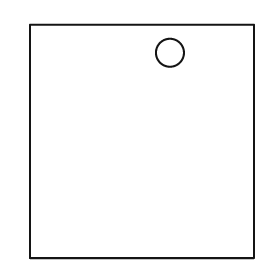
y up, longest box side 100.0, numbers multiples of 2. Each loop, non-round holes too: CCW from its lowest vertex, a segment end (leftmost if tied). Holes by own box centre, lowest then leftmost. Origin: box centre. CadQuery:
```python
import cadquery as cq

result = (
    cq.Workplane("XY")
    .moveTo(-48.0, -50.0)
    .lineTo(48.0, -50.0)
    .lineTo(48.0, 50.0)
    .lineTo(-48.0, 50.0)
    .close()
    .moveTo(12.0, 38.0)
    .circle(6.0)
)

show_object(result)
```